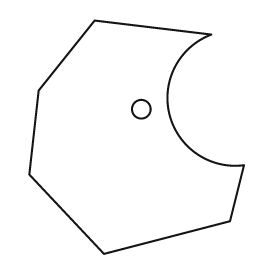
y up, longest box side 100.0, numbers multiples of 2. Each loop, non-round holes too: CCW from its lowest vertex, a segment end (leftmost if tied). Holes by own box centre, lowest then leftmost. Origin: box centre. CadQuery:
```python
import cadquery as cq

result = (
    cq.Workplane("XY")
    .moveTo(-14.0, -50.0)
    .lineTo(40.0, -36.0)
    .lineTo(46.0, -12.0)
    .threePointArc((14.0, 10.0), (32.0, 44.0))
    .lineTo(-18.0, 50.0)
    .lineTo(-42.0, 20.0)
    .lineTo(-46.0, -16.0)
    .close()
    .moveTo(2.0, 12.0)
    .circle(4.0)
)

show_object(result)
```